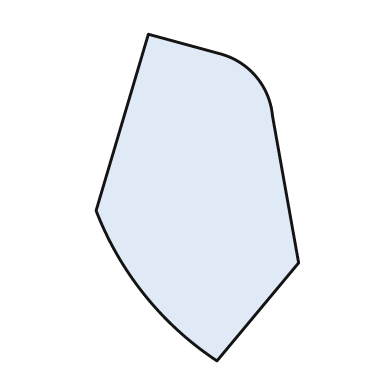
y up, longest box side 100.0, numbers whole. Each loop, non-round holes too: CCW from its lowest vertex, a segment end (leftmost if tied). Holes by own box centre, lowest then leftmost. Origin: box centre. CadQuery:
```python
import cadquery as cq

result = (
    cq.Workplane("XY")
    .moveTo(6.0, -50.0)
    .lineTo(31.0, -20.0)
    .lineTo(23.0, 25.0)
    .threePointArc((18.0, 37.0), (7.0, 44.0))
    .lineTo(-15.0, 50.0)
    .lineTo(-31.0, -4.0)
    .threePointArc((-16.0, -30.0), (6.0, -50.0))
    .close()
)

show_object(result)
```